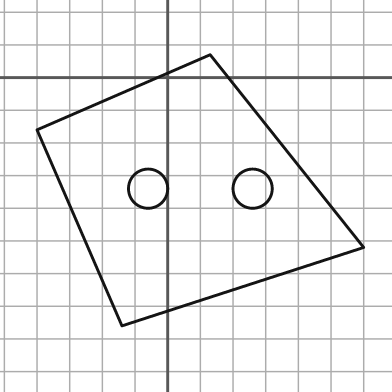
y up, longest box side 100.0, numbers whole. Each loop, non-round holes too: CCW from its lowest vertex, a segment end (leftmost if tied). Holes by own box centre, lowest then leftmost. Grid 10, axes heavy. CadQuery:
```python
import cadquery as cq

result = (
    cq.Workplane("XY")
    .moveTo(-14.0, -76.0)
    .lineTo(60.0, -52.0)
    .lineTo(13.0, 7.0)
    .lineTo(-40.0, -16.0)
    .close()
    .moveTo(-6.0, -34.0)
    .circle(6.0)
    .moveTo(26.0, -34.0)
    .circle(6.0)
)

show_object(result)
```